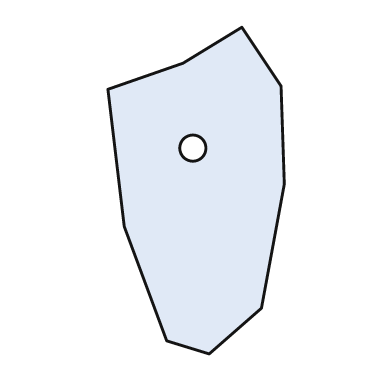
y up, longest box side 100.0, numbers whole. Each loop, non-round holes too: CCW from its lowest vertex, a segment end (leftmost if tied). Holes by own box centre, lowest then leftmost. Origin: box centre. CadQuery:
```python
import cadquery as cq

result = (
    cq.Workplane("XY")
    .moveTo(4.0, -50.0)
    .lineTo(20.0, -36.0)
    .lineTo(27.0, 2.0)
    .lineTo(26.0, 32.0)
    .lineTo(14.0, 50.0)
    .lineTo(-4.0, 39.0)
    .lineTo(-27.0, 31.0)
    .lineTo(-22.0, -11.0)
    .lineTo(-9.0, -46.0)
    .close()
    .moveTo(-1.0, 13.0)
    .circle(4.0)
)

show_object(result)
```